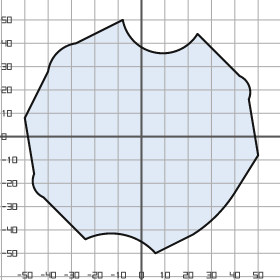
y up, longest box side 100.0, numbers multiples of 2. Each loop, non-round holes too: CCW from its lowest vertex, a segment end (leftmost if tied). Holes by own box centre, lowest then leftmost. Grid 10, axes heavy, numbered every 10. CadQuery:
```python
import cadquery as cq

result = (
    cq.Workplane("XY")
    .moveTo(6.0, -50.0)
    .lineTo(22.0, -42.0)
    .threePointArc((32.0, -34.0), (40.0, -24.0))
    .lineTo(50.0, -8.0)
    .lineTo(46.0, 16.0)
    .threePointArc((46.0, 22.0), (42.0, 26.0))
    .lineTo(24.0, 44.0)
    .threePointArc((6.0, 36.0), (-8.0, 50.0))
    .lineTo(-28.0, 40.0)
    .threePointArc((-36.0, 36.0), (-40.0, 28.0))
    .lineTo(-50.0, 8.0)
    .lineTo(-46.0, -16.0)
    .threePointArc((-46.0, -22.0), (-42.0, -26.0))
    .lineTo(-24.0, -44.0)
    .threePointArc((-8.0, -42.0), (6.0, -50.0))
    .close()
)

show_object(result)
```